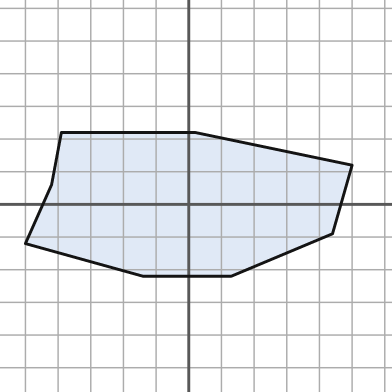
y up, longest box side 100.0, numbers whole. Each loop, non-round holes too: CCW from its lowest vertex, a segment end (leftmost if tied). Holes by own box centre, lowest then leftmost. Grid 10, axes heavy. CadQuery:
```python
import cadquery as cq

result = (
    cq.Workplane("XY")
    .moveTo(-14.0, -22.0)
    .lineTo(13.0, -22.0)
    .lineTo(44.0, -9.0)
    .lineTo(50.0, 12.0)
    .lineTo(2.0, 22.0)
    .lineTo(-39.0, 22.0)
    .lineTo(-42.0, 6.0)
    .lineTo(-50.0, -12.0)
    .close()
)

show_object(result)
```